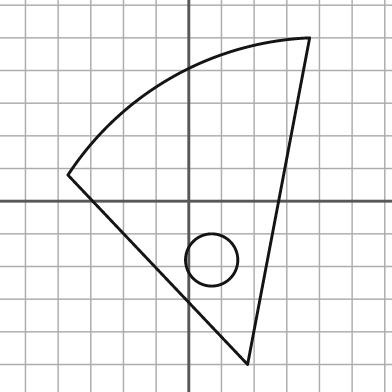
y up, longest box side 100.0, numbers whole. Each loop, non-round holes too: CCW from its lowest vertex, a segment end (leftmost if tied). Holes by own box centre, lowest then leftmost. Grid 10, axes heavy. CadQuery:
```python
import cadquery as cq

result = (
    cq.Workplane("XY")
    .moveTo(18.0, -50.0)
    .lineTo(37.0, 50.0)
    .threePointArc((-5.0, 38.0), (-37.0, 8.0))
    .close()
    .moveTo(7.0, -18.0)
    .circle(8.0)
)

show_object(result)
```